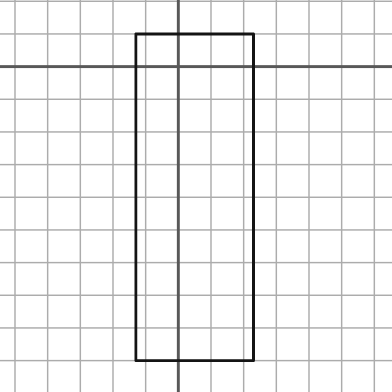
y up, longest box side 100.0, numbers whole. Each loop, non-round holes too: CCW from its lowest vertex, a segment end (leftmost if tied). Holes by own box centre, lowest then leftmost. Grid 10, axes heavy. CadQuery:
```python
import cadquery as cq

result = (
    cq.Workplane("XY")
    .moveTo(-13.0, -90.0)
    .lineTo(23.0, -90.0)
    .lineTo(23.0, 10.0)
    .lineTo(-13.0, 10.0)
    .close()
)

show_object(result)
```